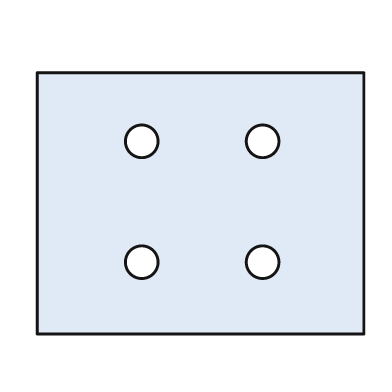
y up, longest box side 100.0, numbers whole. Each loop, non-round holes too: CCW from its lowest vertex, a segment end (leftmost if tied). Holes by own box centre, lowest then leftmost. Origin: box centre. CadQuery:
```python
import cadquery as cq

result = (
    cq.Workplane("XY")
    .moveTo(-50.0, -40.0)
    .lineTo(50.0, -40.0)
    .lineTo(50.0, 40.0)
    .lineTo(-50.0, 40.0)
    .close()
    .moveTo(-18.0, -18.0)
    .circle(5.0)
    .moveTo(19.0, -18.0)
    .circle(5.0)
    .moveTo(-18.0, 19.0)
    .circle(5.0)
    .moveTo(19.0, 19.0)
    .circle(5.0)
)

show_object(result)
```